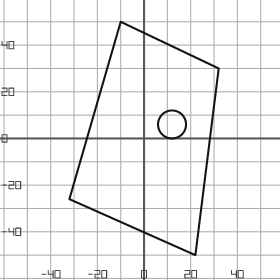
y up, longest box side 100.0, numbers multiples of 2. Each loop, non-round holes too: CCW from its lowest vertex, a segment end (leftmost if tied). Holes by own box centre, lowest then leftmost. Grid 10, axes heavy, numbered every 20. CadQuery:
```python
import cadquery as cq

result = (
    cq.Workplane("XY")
    .moveTo(22.0, -50.0)
    .lineTo(32.0, 30.0)
    .lineTo(-10.0, 50.0)
    .lineTo(-32.0, -26.0)
    .close()
    .moveTo(12.0, 6.0)
    .circle(6.0)
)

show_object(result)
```